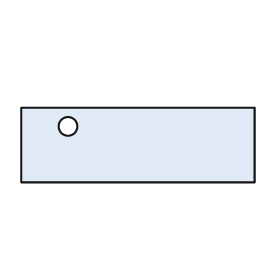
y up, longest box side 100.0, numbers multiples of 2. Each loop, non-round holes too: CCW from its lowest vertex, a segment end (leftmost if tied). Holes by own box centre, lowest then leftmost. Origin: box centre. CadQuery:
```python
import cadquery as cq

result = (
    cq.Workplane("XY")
    .moveTo(-50.0, -16.0)
    .lineTo(50.0, -16.0)
    .lineTo(50.0, 16.0)
    .lineTo(-50.0, 16.0)
    .close()
    .moveTo(-30.0, 8.0)
    .circle(4.0)
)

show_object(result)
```